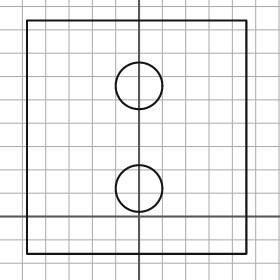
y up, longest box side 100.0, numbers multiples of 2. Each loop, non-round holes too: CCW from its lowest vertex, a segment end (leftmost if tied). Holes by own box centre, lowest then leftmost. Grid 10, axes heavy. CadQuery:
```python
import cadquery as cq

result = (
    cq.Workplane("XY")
    .moveTo(-48.0, -16.0)
    .lineTo(46.0, -16.0)
    .lineTo(46.0, 84.0)
    .lineTo(-48.0, 84.0)
    .close()
    .moveTo(0.0, 12.0)
    .circle(10.0)
    .moveTo(0.0, 56.0)
    .circle(10.0)
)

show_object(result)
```